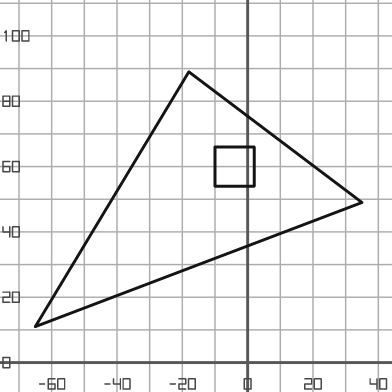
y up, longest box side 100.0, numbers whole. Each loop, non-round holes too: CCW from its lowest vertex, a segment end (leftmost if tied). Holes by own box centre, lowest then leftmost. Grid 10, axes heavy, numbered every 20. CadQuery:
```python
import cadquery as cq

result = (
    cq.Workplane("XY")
    .moveTo(-65.0, 11.0)
    .lineTo(35.0, 49.0)
    .lineTo(-18.0, 89.0)
    .close()
    .moveTo(-10.0, 54.0)
    .lineTo(2.0, 54.0)
    .lineTo(2.0, 66.0)
    .lineTo(-10.0, 66.0)
    .close()
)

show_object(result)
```